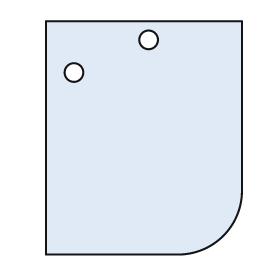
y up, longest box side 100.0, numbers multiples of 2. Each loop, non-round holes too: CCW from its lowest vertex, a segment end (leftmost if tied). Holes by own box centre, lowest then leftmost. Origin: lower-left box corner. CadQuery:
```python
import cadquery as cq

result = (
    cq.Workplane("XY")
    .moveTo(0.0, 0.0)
    .lineTo(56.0, 0.0)
    .threePointArc((76.0, 8.0), (84.0, 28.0))
    .lineTo(84.0, 100.0)
    .lineTo(0.0, 100.0)
    .close()
    .moveTo(12.0, 78.0)
    .circle(4.0)
    .moveTo(44.0, 92.0)
    .circle(4.0)
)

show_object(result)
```